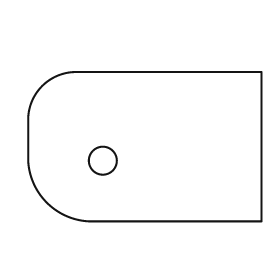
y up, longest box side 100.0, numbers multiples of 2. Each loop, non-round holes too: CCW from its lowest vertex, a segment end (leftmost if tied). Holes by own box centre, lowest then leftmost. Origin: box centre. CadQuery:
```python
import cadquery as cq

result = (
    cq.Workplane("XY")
    .moveTo(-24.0, -32.0)
    .lineTo(50.0, -32.0)
    .lineTo(50.0, 32.0)
    .lineTo(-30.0, 32.0)
    .threePointArc((-44.0, 26.0), (-50.0, 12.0))
    .lineTo(-50.0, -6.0)
    .threePointArc((-42.0, -24.0), (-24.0, -32.0))
    .close()
    .moveTo(-18.0, -6.0)
    .circle(6.0)
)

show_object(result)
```